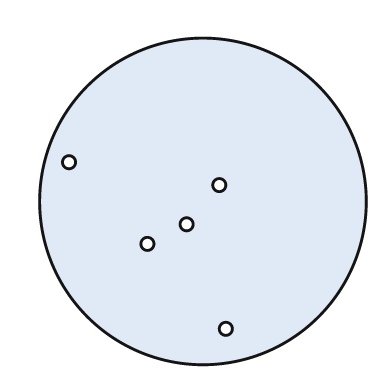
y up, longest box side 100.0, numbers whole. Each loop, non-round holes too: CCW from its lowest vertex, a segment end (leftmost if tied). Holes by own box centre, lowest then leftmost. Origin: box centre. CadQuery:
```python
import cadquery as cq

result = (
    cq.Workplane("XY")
    .moveTo(0.0, 0.0)
    .circle(50.0)
    .moveTo(7.0, -39.0)
    .circle(2.0)
    .moveTo(-17.0, -13.0)
    .circle(2.0)
    .moveTo(-5.0, -7.0)
    .circle(2.0)
    .moveTo(5.0, 5.0)
    .circle(2.0)
    .moveTo(-41.0, 12.0)
    .circle(2.0)
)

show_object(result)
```